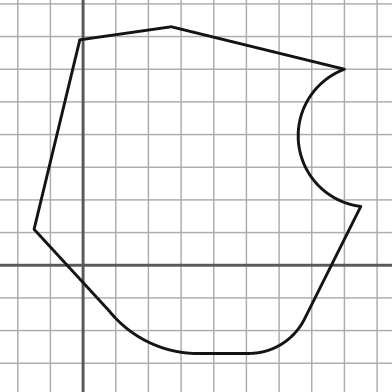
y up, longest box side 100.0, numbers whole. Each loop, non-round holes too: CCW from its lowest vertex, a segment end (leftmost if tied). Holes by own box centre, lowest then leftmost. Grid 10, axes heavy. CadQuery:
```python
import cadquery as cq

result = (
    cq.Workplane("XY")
    .moveTo(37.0, -27.0)
    .lineTo(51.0, -27.0)
    .threePointArc((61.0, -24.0), (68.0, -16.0))
    .lineTo(85.0, 18.0)
    .threePointArc((66.0, 37.0), (80.0, 60.0))
    .lineTo(27.0, 73.0)
    .lineTo(-1.0, 69.0)
    .lineTo(-15.0, 11.0)
    .lineTo(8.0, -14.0)
    .threePointArc((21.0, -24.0), (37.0, -27.0))
    .close()
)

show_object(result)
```